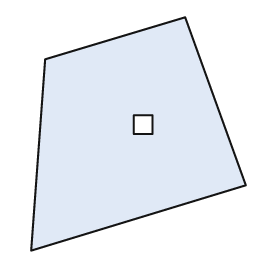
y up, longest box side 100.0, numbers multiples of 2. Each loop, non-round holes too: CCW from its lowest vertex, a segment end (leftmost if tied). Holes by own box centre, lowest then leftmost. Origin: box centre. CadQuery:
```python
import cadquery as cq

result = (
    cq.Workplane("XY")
    .moveTo(-46.0, -50.0)
    .lineTo(46.0, -22.0)
    .lineTo(20.0, 50.0)
    .lineTo(-40.0, 32.0)
    .close()
    .moveTo(-2.0, 0.0)
    .lineTo(6.0, 0.0)
    .lineTo(6.0, 8.0)
    .lineTo(-2.0, 8.0)
    .close()
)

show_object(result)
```